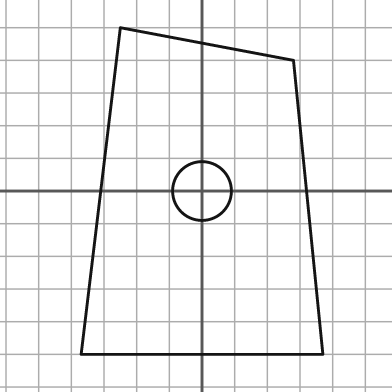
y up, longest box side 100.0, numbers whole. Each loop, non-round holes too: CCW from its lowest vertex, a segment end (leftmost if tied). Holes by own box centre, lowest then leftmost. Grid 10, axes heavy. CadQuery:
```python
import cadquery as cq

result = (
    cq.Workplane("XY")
    .moveTo(-37.0, -50.0)
    .lineTo(37.0, -50.0)
    .lineTo(28.0, 40.0)
    .lineTo(-25.0, 50.0)
    .close()
    .moveTo(0.0, 0.0)
    .circle(9.0)
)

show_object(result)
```